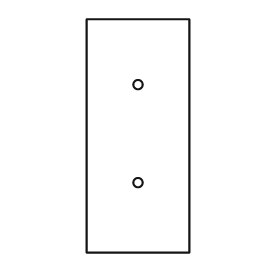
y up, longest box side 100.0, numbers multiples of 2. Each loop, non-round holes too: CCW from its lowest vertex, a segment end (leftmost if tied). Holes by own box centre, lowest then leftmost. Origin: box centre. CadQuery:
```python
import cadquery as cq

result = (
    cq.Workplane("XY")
    .moveTo(-22.0, -50.0)
    .lineTo(22.0, -50.0)
    .lineTo(22.0, 50.0)
    .lineTo(-22.0, 50.0)
    .close()
    .moveTo(0.0, -20.0)
    .circle(2.0)
    .moveTo(0.0, 22.0)
    .circle(2.0)
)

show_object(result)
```